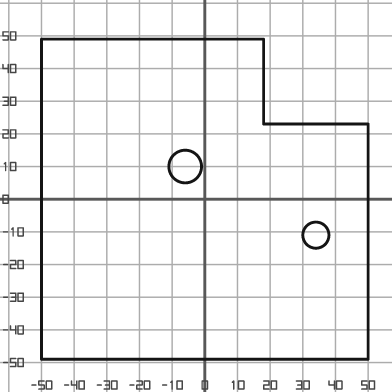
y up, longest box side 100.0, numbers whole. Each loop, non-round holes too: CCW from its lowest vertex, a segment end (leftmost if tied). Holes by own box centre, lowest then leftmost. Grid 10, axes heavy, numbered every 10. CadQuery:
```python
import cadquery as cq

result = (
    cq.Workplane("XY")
    .moveTo(-50.0, -49.0)
    .lineTo(50.0, -49.0)
    .lineTo(50.0, 23.0)
    .lineTo(18.0, 23.0)
    .lineTo(18.0, 49.0)
    .lineTo(-50.0, 49.0)
    .close()
    .moveTo(34.0, -11.0)
    .circle(4.0)
    .moveTo(-6.0, 10.0)
    .circle(5.0)
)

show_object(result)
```